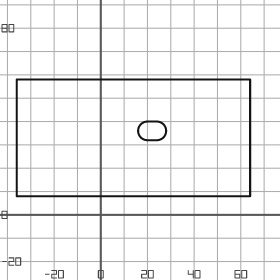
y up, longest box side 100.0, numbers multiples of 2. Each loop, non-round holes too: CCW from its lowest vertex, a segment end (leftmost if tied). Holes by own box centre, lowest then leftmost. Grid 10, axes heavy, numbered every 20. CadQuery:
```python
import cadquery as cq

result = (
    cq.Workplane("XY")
    .moveTo(-36.0, 8.0)
    .lineTo(64.0, 8.0)
    .lineTo(64.0, 58.0)
    .lineTo(-36.0, 58.0)
    .close()
    .moveTo(20.0, 32.0)
    .lineTo(24.0, 32.0)
    .threePointArc((28.0, 36.0), (24.0, 40.0))
    .lineTo(20.0, 40.0)
    .threePointArc((16.0, 36.0), (20.0, 32.0))
    .close()
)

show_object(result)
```